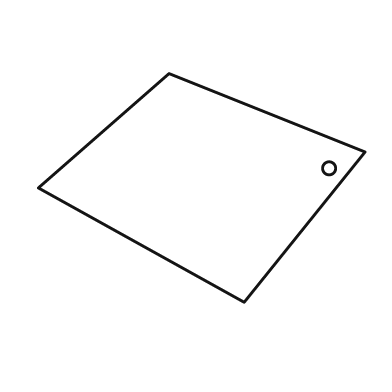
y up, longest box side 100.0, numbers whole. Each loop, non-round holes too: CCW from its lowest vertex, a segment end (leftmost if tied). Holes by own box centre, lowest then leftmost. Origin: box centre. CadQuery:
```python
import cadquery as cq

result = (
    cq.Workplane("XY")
    .moveTo(13.0, -35.0)
    .lineTo(50.0, 11.0)
    .lineTo(-10.0, 35.0)
    .lineTo(-50.0, 0.0)
    .close()
    .moveTo(39.0, 6.0)
    .circle(2.0)
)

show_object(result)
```